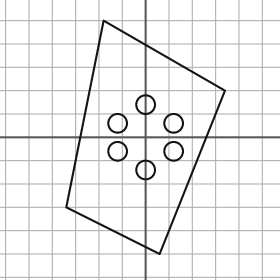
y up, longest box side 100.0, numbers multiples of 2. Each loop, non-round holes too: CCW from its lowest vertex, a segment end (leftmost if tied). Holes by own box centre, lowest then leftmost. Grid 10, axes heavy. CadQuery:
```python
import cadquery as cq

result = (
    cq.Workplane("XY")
    .moveTo(6.0, -50.0)
    .lineTo(34.0, 20.0)
    .lineTo(-18.0, 50.0)
    .lineTo(-34.0, -30.0)
    .close()
    .moveTo(0.0, -14.0)
    .circle(4.0)
    .moveTo(-12.0, -6.0)
    .circle(4.0)
    .moveTo(12.0, -6.0)
    .circle(4.0)
    .moveTo(-12.0, 6.0)
    .circle(4.0)
    .moveTo(12.0, 6.0)
    .circle(4.0)
    .moveTo(0.0, 14.0)
    .circle(4.0)
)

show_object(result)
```